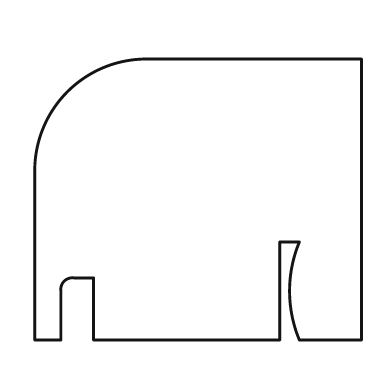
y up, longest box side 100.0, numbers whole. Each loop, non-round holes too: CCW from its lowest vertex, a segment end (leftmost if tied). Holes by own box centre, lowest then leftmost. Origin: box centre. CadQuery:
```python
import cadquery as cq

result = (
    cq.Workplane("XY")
    .moveTo(-50.0, -43.0)
    .lineTo(-42.0, -43.0)
    .lineTo(-42.0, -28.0)
    .threePointArc((-41.0, -25.0), (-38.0, -24.0))
    .lineTo(-32.0, -24.0)
    .lineTo(-32.0, -43.0)
    .lineTo(25.0, -43.0)
    .lineTo(25.0, -13.0)
    .lineTo(31.0, -13.0)
    .threePointArc((28.0, -28.0), (31.0, -43.0))
    .lineTo(50.0, -43.0)
    .lineTo(50.0, 43.0)
    .lineTo(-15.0, 43.0)
    .threePointArc((-40.0, 33.0), (-50.0, 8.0))
    .close()
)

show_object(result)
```